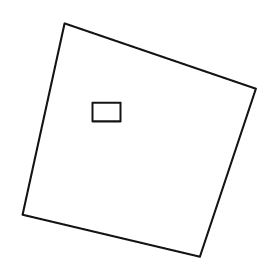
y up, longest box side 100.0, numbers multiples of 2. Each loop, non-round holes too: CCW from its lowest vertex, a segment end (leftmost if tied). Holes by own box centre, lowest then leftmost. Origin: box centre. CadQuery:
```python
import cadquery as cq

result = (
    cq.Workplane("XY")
    .moveTo(26.0, -50.0)
    .lineTo(50.0, 22.0)
    .lineTo(-32.0, 50.0)
    .lineTo(-50.0, -32.0)
    .close()
    .moveTo(-20.0, 8.0)
    .lineTo(-8.0, 8.0)
    .lineTo(-8.0, 16.0)
    .lineTo(-20.0, 16.0)
    .close()
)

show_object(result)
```